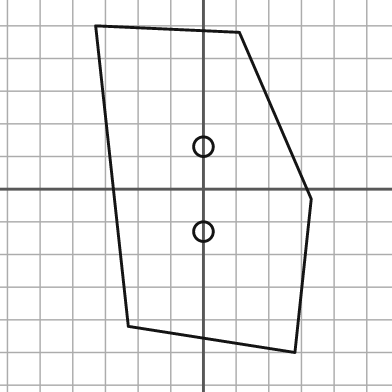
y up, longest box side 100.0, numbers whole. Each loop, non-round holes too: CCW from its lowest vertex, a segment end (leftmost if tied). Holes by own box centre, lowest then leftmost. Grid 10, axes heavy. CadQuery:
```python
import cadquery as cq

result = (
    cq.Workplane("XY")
    .moveTo(28.0, -50.0)
    .lineTo(33.0, -3.0)
    .lineTo(11.0, 48.0)
    .lineTo(-33.0, 50.0)
    .lineTo(-23.0, -42.0)
    .close()
    .moveTo(0.0, -13.0)
    .circle(3.0)
    .moveTo(0.0, 13.0)
    .circle(3.0)
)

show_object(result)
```